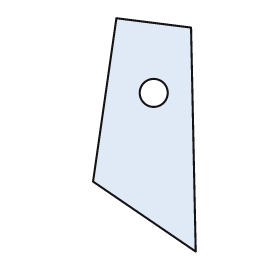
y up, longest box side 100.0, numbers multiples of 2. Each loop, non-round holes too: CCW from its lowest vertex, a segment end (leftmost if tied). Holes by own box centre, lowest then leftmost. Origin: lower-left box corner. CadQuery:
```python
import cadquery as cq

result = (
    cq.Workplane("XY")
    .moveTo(44.0, 0.0)
    .lineTo(42.0, 96.0)
    .lineTo(10.0, 100.0)
    .lineTo(0.0, 30.0)
    .close()
    .moveTo(26.0, 68.0)
    .circle(6.0)
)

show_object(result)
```